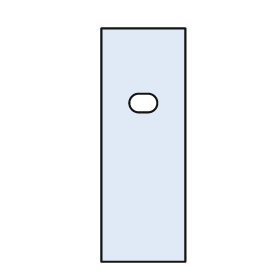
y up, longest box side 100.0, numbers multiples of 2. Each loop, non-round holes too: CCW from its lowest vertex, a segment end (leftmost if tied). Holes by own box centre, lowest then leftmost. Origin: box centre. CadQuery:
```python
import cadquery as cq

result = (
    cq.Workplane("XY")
    .moveTo(-18.0, -50.0)
    .lineTo(18.0, -50.0)
    .lineTo(18.0, 50.0)
    .lineTo(-18.0, 50.0)
    .close()
    .moveTo(-2.0, 14.0)
    .lineTo(2.0, 14.0)
    .threePointArc((6.0, 18.0), (2.0, 22.0))
    .lineTo(-2.0, 22.0)
    .threePointArc((-6.0, 18.0), (-2.0, 14.0))
    .close()
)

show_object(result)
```